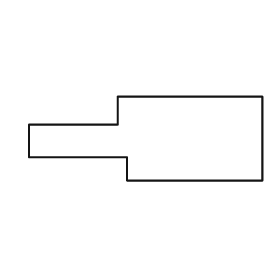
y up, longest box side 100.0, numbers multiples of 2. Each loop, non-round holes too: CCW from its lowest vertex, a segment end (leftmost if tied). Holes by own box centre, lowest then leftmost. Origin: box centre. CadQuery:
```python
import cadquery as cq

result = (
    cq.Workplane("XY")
    .moveTo(-8.0, -18.0)
    .lineTo(50.0, -18.0)
    .lineTo(50.0, 18.0)
    .lineTo(-12.0, 18.0)
    .lineTo(-12.0, 6.0)
    .lineTo(-50.0, 6.0)
    .lineTo(-50.0, -8.0)
    .lineTo(-8.0, -8.0)
    .close()
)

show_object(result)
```